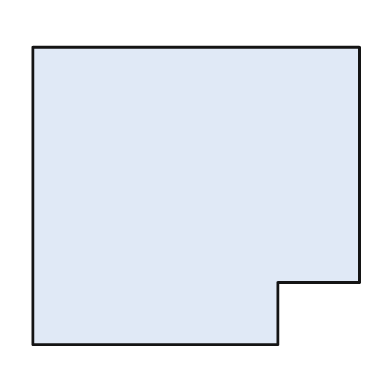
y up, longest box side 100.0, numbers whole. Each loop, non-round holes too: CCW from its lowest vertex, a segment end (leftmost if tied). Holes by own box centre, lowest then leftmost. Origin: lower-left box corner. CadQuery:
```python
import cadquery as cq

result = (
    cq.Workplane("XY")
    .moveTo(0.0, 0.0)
    .lineTo(75.0, 0.0)
    .lineTo(75.0, 19.0)
    .lineTo(100.0, 19.0)
    .lineTo(100.0, 91.0)
    .lineTo(0.0, 91.0)
    .close()
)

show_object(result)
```